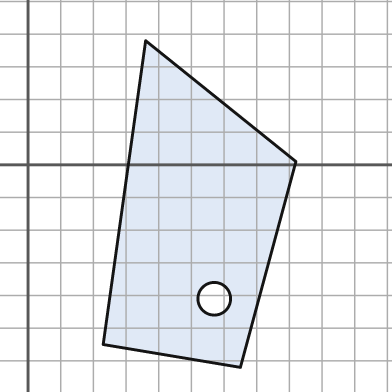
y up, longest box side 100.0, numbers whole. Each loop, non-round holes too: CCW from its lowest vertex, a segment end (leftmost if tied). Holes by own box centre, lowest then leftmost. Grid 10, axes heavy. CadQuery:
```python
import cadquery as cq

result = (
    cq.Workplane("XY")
    .moveTo(65.0, -62.0)
    .lineTo(82.0, 1.0)
    .lineTo(36.0, 38.0)
    .lineTo(23.0, -55.0)
    .close()
    .moveTo(57.0, -41.0)
    .circle(5.0)
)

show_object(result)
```